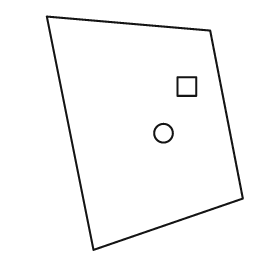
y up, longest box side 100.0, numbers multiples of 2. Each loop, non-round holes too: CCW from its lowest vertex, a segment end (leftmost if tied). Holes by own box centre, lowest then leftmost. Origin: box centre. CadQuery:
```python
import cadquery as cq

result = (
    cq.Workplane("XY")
    .moveTo(-22.0, -50.0)
    .lineTo(42.0, -28.0)
    .lineTo(28.0, 44.0)
    .lineTo(-42.0, 50.0)
    .close()
    .moveTo(8.0, 0.0)
    .circle(4.0)
    .moveTo(14.0, 16.0)
    .lineTo(22.0, 16.0)
    .lineTo(22.0, 24.0)
    .lineTo(14.0, 24.0)
    .close()
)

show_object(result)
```